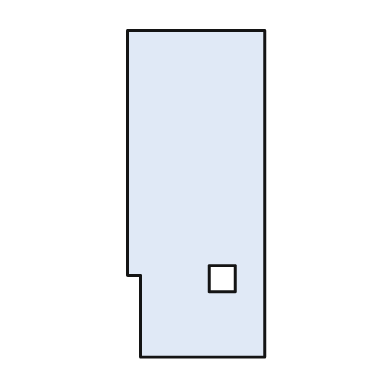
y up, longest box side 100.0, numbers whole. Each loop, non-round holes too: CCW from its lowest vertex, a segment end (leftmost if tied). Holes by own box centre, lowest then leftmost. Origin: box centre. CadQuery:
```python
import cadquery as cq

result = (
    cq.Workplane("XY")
    .moveTo(-17.0, -50.0)
    .lineTo(21.0, -50.0)
    .lineTo(21.0, 50.0)
    .lineTo(-21.0, 50.0)
    .lineTo(-21.0, -25.0)
    .lineTo(-17.0, -25.0)
    .close()
    .moveTo(4.0, -30.0)
    .lineTo(12.0, -30.0)
    .lineTo(12.0, -22.0)
    .lineTo(4.0, -22.0)
    .close()
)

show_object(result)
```